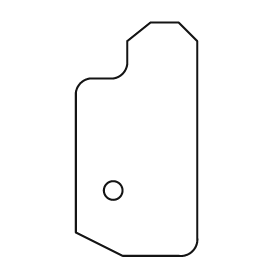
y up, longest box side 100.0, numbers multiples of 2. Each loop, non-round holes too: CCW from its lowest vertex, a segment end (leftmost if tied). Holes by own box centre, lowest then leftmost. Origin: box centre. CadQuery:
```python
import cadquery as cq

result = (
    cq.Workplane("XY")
    .moveTo(-6.0, -50.0)
    .lineTo(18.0, -50.0)
    .threePointArc((24.0, -48.0), (26.0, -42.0))
    .lineTo(26.0, 42.0)
    .lineTo(18.0, 50.0)
    .lineTo(6.0, 50.0)
    .lineTo(-4.0, 42.0)
    .lineTo(-4.0, 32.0)
    .threePointArc((-6.0, 28.0), (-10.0, 26.0))
    .lineTo(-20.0, 26.0)
    .threePointArc((-24.0, 24.0), (-26.0, 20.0))
    .lineTo(-26.0, -40.0)
    .close()
    .moveTo(-10.0, -22.0)
    .circle(4.0)
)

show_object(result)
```